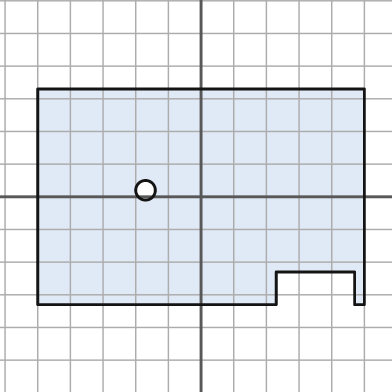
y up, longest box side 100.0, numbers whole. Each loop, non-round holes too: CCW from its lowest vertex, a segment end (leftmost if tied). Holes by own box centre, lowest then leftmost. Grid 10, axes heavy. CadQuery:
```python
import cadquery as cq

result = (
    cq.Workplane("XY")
    .moveTo(-50.0, -33.0)
    .lineTo(23.0, -33.0)
    .lineTo(23.0, -23.0)
    .lineTo(47.0, -23.0)
    .lineTo(47.0, -33.0)
    .lineTo(50.0, -33.0)
    .lineTo(50.0, 33.0)
    .lineTo(-50.0, 33.0)
    .close()
    .moveTo(-17.0, 2.0)
    .circle(3.0)
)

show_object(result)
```